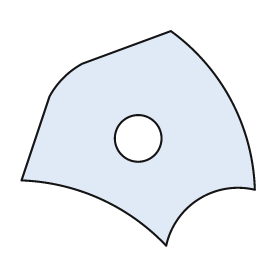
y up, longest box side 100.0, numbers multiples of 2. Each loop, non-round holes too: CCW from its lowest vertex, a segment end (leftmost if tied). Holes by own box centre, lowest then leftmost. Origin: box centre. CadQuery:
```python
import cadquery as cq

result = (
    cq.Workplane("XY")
    .moveTo(12.0, -46.0)
    .threePointArc((26.0, -26.0), (50.0, -22.0))
    .threePointArc((40.0, 16.0), (14.0, 46.0))
    .lineTo(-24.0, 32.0)
    .threePointArc((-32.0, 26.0), (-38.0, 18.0))
    .lineTo(-50.0, -18.0)
    .threePointArc((-16.0, -26.0), (12.0, -46.0))
    .close()
    .moveTo(0.0, 0.0)
    .circle(10.0)
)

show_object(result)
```